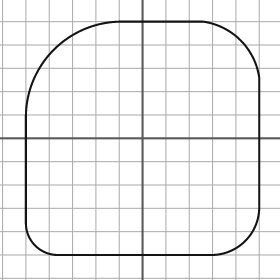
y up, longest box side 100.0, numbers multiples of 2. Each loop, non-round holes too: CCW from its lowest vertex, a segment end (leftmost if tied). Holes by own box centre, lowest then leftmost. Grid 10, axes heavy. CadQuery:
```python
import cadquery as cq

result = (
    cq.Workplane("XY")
    .moveTo(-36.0, -50.0)
    .lineTo(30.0, -50.0)
    .threePointArc((44.0, -44.0), (50.0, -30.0))
    .lineTo(50.0, 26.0)
    .threePointArc((42.0, 42.0), (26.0, 50.0))
    .lineTo(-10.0, 50.0)
    .threePointArc((-38.0, 38.0), (-50.0, 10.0))
    .lineTo(-50.0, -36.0)
    .threePointArc((-46.0, -46.0), (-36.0, -50.0))
    .close()
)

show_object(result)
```